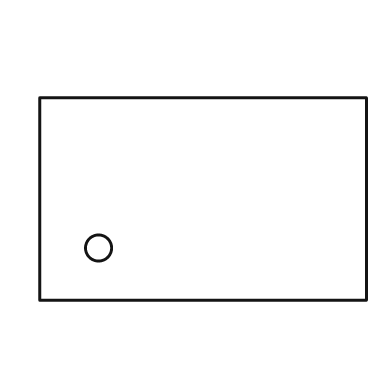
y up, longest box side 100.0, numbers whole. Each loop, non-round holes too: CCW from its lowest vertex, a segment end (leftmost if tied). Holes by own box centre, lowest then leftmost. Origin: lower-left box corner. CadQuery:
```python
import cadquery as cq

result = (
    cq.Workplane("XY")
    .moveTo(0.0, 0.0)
    .lineTo(100.0, 0.0)
    .lineTo(100.0, 62.0)
    .lineTo(0.0, 62.0)
    .close()
    .moveTo(18.0, 16.0)
    .circle(4.0)
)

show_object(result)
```